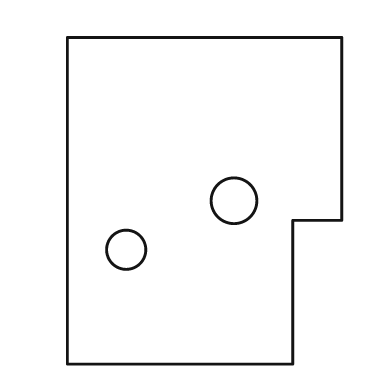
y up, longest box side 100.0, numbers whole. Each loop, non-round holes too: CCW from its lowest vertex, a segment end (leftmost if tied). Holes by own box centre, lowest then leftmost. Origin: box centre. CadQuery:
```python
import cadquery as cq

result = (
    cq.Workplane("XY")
    .moveTo(-42.0, -50.0)
    .lineTo(27.0, -50.0)
    .lineTo(27.0, -6.0)
    .lineTo(42.0, -6.0)
    .lineTo(42.0, 50.0)
    .lineTo(-42.0, 50.0)
    .close()
    .moveTo(-24.0, -15.0)
    .circle(6.0)
    .moveTo(9.0, 0.0)
    .circle(7.0)
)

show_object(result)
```